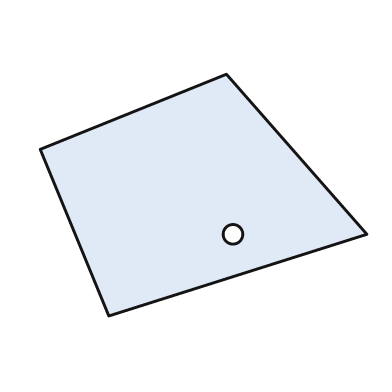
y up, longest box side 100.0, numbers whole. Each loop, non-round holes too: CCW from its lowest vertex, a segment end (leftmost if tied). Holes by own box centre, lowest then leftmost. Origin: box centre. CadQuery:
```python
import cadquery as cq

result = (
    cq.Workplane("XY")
    .moveTo(-29.0, -37.0)
    .lineTo(50.0, -12.0)
    .lineTo(7.0, 37.0)
    .lineTo(-50.0, 14.0)
    .close()
    .moveTo(9.0, -12.0)
    .circle(3.0)
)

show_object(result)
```